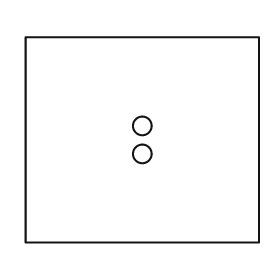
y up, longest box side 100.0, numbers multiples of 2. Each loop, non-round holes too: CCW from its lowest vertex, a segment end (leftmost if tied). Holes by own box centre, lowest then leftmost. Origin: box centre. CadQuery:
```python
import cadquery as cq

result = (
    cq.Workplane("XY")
    .moveTo(-50.0, -44.0)
    .lineTo(50.0, -44.0)
    .lineTo(50.0, 44.0)
    .lineTo(-50.0, 44.0)
    .close()
    .moveTo(0.0, -6.0)
    .circle(4.0)
    .moveTo(0.0, 6.0)
    .circle(4.0)
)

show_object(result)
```